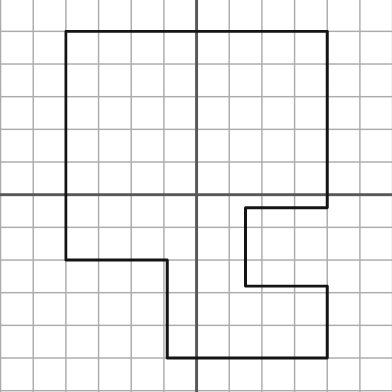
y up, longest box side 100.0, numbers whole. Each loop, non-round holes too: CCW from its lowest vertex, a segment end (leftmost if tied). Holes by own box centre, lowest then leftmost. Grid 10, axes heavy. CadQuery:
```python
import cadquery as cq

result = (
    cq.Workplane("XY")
    .moveTo(-9.0, -50.0)
    .lineTo(40.0, -50.0)
    .lineTo(40.0, -28.0)
    .lineTo(15.0, -28.0)
    .lineTo(15.0, -4.0)
    .lineTo(40.0, -4.0)
    .lineTo(40.0, 50.0)
    .lineTo(-40.0, 50.0)
    .lineTo(-40.0, -20.0)
    .lineTo(-9.0, -20.0)
    .close()
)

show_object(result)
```